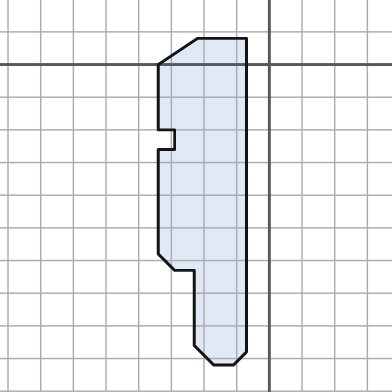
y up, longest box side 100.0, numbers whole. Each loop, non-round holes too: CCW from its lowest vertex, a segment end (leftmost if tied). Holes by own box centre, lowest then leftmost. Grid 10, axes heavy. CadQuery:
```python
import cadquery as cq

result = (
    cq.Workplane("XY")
    .moveTo(-17.0, -92.0)
    .lineTo(-11.0, -92.0)
    .lineTo(-7.0, -88.0)
    .lineTo(-7.0, 8.0)
    .lineTo(-22.0, 8.0)
    .lineTo(-34.0, 0.0)
    .lineTo(-34.0, -20.0)
    .lineTo(-29.0, -20.0)
    .lineTo(-29.0, -26.0)
    .lineTo(-34.0, -26.0)
    .lineTo(-34.0, -58.0)
    .lineTo(-29.0, -63.0)
    .lineTo(-23.0, -63.0)
    .lineTo(-23.0, -86.0)
    .close()
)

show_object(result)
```